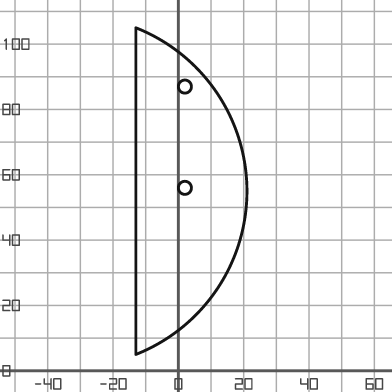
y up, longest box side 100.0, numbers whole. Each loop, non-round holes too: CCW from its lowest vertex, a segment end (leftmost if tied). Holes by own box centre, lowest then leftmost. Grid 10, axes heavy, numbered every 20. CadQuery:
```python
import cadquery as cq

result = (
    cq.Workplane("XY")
    .moveTo(-13.0, 5.0)
    .threePointArc((21.0, 55.0), (-13.0, 105.0))
    .close()
    .moveTo(2.0, 56.0)
    .circle(2.0)
    .moveTo(2.0, 87.0)
    .circle(2.0)
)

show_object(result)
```